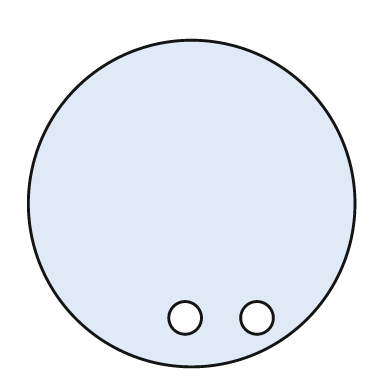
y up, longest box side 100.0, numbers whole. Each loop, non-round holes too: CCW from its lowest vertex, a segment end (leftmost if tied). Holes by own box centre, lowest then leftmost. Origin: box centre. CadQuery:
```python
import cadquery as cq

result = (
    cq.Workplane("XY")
    .moveTo(0.0, 0.0)
    .circle(50.0)
    .moveTo(-2.0, -35.0)
    .circle(5.0)
    .moveTo(20.0, -35.0)
    .circle(5.0)
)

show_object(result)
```